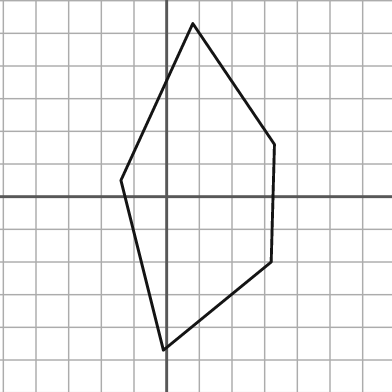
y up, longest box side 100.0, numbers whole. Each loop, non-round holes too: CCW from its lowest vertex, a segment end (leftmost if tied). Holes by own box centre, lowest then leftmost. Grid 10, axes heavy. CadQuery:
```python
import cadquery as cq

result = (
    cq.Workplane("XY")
    .moveTo(-1.0, -47.0)
    .lineTo(32.0, -20.0)
    .lineTo(33.0, 16.0)
    .lineTo(8.0, 53.0)
    .lineTo(-14.0, 5.0)
    .close()
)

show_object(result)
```